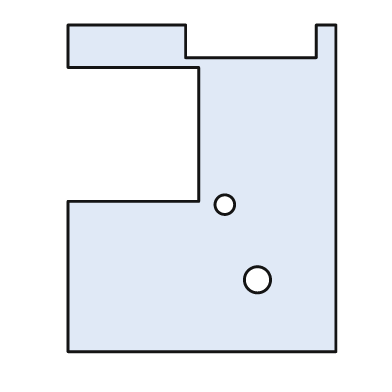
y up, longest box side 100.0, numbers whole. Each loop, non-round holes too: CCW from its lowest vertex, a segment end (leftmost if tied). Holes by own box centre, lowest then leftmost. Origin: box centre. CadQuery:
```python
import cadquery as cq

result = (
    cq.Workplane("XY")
    .moveTo(-41.0, -50.0)
    .lineTo(41.0, -50.0)
    .lineTo(41.0, 50.0)
    .lineTo(35.0, 50.0)
    .lineTo(35.0, 40.0)
    .lineTo(-5.0, 40.0)
    .lineTo(-5.0, 50.0)
    .lineTo(-41.0, 50.0)
    .lineTo(-41.0, 37.0)
    .lineTo(-1.0, 37.0)
    .lineTo(-1.0, -4.0)
    .lineTo(-41.0, -4.0)
    .close()
    .moveTo(17.0, -28.0)
    .circle(4.0)
    .moveTo(7.0, -5.0)
    .circle(3.0)
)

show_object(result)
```